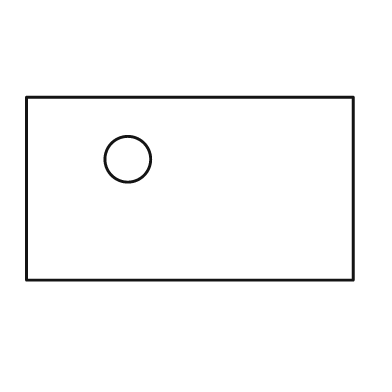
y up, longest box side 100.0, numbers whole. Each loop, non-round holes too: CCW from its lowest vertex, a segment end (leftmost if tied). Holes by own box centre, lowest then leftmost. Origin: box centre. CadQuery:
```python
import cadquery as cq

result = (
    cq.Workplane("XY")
    .moveTo(-50.0, -28.0)
    .lineTo(50.0, -28.0)
    .lineTo(50.0, 28.0)
    .lineTo(-50.0, 28.0)
    .close()
    .moveTo(-19.0, 9.0)
    .circle(7.0)
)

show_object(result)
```